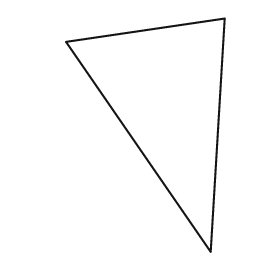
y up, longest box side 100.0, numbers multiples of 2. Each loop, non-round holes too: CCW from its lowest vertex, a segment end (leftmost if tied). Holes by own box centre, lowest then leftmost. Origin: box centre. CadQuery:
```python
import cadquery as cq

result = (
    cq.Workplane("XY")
    .moveTo(28.0, -50.0)
    .lineTo(34.0, 50.0)
    .lineTo(-34.0, 40.0)
    .close()
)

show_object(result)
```